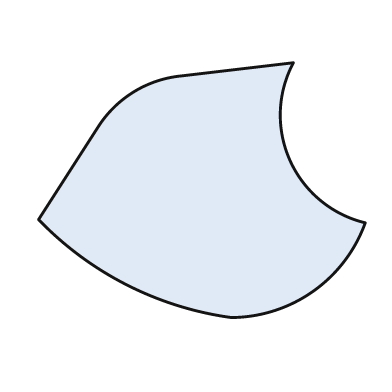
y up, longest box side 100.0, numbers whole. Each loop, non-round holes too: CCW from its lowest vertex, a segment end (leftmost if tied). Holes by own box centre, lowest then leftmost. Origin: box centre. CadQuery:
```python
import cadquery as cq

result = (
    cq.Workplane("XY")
    .moveTo(9.0, -39.0)
    .threePointArc((34.0, -31.0), (50.0, -10.0))
    .threePointArc((27.0, 9.0), (28.0, 39.0))
    .lineTo(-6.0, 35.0)
    .threePointArc((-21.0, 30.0), (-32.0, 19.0))
    .lineTo(-50.0, -9.0)
    .threePointArc((-23.0, -29.0), (9.0, -39.0))
    .close()
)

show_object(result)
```